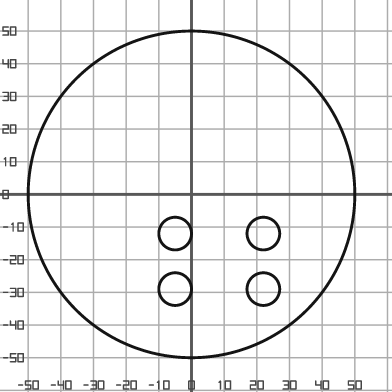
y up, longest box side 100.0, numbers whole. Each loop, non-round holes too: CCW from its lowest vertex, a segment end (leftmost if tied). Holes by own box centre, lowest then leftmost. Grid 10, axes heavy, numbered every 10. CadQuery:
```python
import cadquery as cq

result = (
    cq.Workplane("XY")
    .moveTo(0.0, 0.0)
    .circle(50.0)
    .moveTo(-5.0, -29.0)
    .circle(5.0)
    .moveTo(22.0, -29.0)
    .circle(5.0)
    .moveTo(-5.0, -12.0)
    .circle(5.0)
    .moveTo(22.0, -12.0)
    .circle(5.0)
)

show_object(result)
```